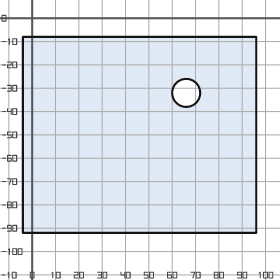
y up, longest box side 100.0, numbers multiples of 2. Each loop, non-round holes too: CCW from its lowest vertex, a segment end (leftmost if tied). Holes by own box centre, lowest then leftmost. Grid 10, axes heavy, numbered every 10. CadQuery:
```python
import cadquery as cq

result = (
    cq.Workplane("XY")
    .moveTo(-4.0, -92.0)
    .lineTo(96.0, -92.0)
    .lineTo(96.0, -8.0)
    .lineTo(-4.0, -8.0)
    .close()
    .moveTo(66.0, -32.0)
    .circle(6.0)
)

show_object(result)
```